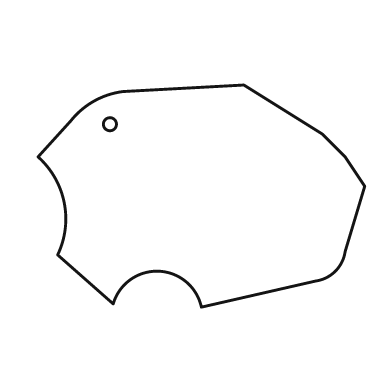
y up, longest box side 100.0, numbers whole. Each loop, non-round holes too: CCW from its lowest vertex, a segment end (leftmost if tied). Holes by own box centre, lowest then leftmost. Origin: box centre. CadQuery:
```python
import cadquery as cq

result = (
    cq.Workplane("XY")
    .moveTo(0.0, -34.0)
    .lineTo(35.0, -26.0)
    .threePointArc((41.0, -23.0), (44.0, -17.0))
    .lineTo(50.0, 3.0)
    .lineTo(44.0, 12.0)
    .lineTo(37.0, 19.0)
    .lineTo(13.0, 34.0)
    .lineTo(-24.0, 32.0)
    .threePointArc((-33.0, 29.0), (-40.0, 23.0))
    .lineTo(-50.0, 12.0)
    .threePointArc((-42.0, -2.0), (-44.0, -18.0))
    .lineTo(-27.0, -33.0)
    .threePointArc((-13.0, -23.0), (0.0, -34.0))
    .close()
    .moveTo(-28.0, 22.0)
    .circle(2.0)
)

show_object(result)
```